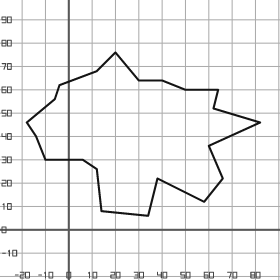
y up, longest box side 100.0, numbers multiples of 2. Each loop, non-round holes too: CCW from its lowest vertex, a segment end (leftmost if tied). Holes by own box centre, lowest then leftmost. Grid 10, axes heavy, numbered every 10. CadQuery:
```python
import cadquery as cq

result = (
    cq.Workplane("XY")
    .moveTo(34.0, 6.0)
    .lineTo(38.0, 22.0)
    .lineTo(58.0, 12.0)
    .lineTo(66.0, 22.0)
    .lineTo(60.0, 36.0)
    .lineTo(82.0, 46.0)
    .lineTo(62.0, 52.0)
    .lineTo(64.0, 60.0)
    .lineTo(50.0, 60.0)
    .lineTo(40.0, 64.0)
    .lineTo(30.0, 64.0)
    .lineTo(20.0, 76.0)
    .lineTo(12.0, 68.0)
    .lineTo(-4.0, 62.0)
    .lineTo(-6.0, 56.0)
    .lineTo(-18.0, 46.0)
    .lineTo(-14.0, 40.0)
    .lineTo(-10.0, 30.0)
    .lineTo(6.0, 30.0)
    .lineTo(12.0, 26.0)
    .lineTo(14.0, 8.0)
    .close()
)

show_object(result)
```